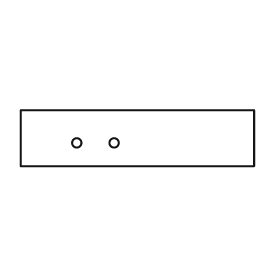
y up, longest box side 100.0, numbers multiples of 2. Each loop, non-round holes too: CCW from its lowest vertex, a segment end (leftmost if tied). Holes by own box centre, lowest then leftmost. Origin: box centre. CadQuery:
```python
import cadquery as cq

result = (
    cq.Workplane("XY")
    .moveTo(-50.0, -12.0)
    .lineTo(50.0, -12.0)
    .lineTo(50.0, 12.0)
    .lineTo(-50.0, 12.0)
    .close()
    .moveTo(-26.0, -2.0)
    .circle(2.0)
    .moveTo(-10.0, -2.0)
    .circle(2.0)
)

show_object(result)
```